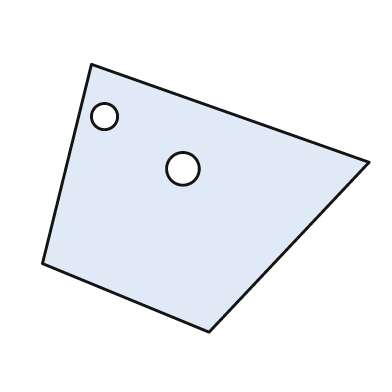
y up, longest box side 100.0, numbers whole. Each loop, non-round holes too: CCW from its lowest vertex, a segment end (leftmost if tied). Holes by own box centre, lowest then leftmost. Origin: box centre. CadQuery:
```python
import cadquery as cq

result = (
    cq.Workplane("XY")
    .moveTo(1.0, -41.0)
    .lineTo(50.0, 11.0)
    .lineTo(-35.0, 41.0)
    .lineTo(-50.0, -20.0)
    .close()
    .moveTo(-7.0, 9.0)
    .circle(5.0)
    .moveTo(-31.0, 25.0)
    .circle(4.0)
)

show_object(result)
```